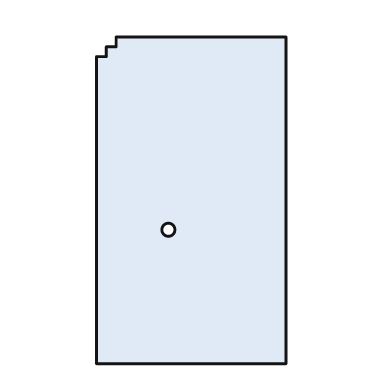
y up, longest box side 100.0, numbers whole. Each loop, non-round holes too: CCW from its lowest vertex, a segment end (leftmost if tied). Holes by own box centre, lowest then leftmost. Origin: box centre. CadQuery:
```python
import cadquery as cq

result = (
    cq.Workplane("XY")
    .moveTo(-29.0, -50.0)
    .lineTo(29.0, -50.0)
    .lineTo(29.0, 50.0)
    .lineTo(-23.0, 50.0)
    .lineTo(-23.0, 47.0)
    .lineTo(-26.0, 47.0)
    .lineTo(-26.0, 44.0)
    .lineTo(-29.0, 44.0)
    .close()
    .moveTo(-7.0, -9.0)
    .circle(2.0)
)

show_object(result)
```